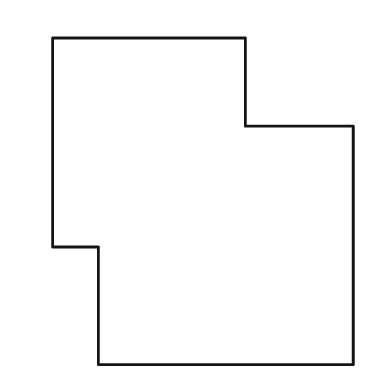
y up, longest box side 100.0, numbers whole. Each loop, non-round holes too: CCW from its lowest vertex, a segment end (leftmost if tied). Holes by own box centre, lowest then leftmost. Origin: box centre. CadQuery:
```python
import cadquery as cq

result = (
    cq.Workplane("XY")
    .moveTo(-32.0, -50.0)
    .lineTo(46.0, -50.0)
    .lineTo(46.0, 23.0)
    .lineTo(13.0, 23.0)
    .lineTo(13.0, 50.0)
    .lineTo(-46.0, 50.0)
    .lineTo(-46.0, -14.0)
    .lineTo(-32.0, -14.0)
    .close()
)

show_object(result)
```